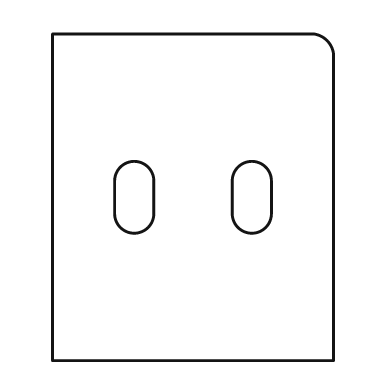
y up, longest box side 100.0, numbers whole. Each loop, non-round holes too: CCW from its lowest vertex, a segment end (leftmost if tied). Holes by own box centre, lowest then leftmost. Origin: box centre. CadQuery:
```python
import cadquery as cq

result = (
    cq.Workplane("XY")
    .moveTo(-43.0, -50.0)
    .lineTo(43.0, -50.0)
    .lineTo(43.0, 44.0)
    .threePointArc((41.0, 48.0), (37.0, 50.0))
    .lineTo(-43.0, 50.0)
    .close()
    .moveTo(-24.0, -5.0)
    .threePointArc((-18.0, -11.0), (-12.0, -5.0))
    .lineTo(-12.0, 5.0)
    .threePointArc((-18.0, 11.0), (-24.0, 5.0))
    .close()
    .moveTo(12.0, -5.0)
    .threePointArc((18.0, -11.0), (24.0, -5.0))
    .lineTo(24.0, 5.0)
    .threePointArc((18.0, 11.0), (12.0, 5.0))
    .close()
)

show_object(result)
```